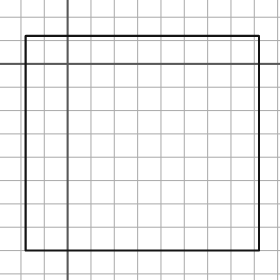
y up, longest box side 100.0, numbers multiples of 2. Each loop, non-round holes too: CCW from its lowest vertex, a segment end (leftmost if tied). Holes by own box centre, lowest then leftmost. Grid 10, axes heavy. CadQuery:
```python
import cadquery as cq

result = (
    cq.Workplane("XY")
    .moveTo(-18.0, -80.0)
    .lineTo(82.0, -80.0)
    .lineTo(82.0, 12.0)
    .lineTo(-18.0, 12.0)
    .close()
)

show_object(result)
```